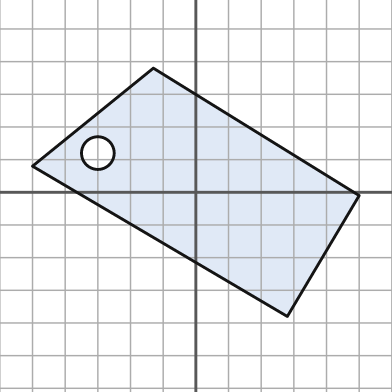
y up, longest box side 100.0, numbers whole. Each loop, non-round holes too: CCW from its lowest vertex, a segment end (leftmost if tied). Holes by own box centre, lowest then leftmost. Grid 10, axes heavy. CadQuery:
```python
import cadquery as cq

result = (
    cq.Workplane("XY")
    .moveTo(28.0, -38.0)
    .lineTo(50.0, -1.0)
    .lineTo(-13.0, 38.0)
    .lineTo(-50.0, 8.0)
    .close()
    .moveTo(-30.0, 12.0)
    .circle(5.0)
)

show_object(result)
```